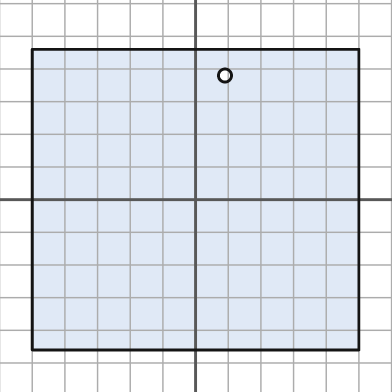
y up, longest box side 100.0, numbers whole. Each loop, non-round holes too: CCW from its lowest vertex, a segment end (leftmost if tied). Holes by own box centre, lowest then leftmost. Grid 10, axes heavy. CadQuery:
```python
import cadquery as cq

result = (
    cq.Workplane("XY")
    .moveTo(-50.0, -46.0)
    .lineTo(50.0, -46.0)
    .lineTo(50.0, 46.0)
    .lineTo(-50.0, 46.0)
    .close()
    .moveTo(9.0, 38.0)
    .circle(2.0)
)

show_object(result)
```